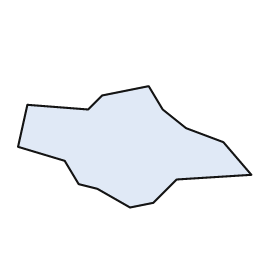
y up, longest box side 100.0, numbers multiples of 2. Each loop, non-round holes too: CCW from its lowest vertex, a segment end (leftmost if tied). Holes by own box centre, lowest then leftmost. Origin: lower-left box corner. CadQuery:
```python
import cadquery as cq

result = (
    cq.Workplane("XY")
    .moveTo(48.0, 0.0)
    .lineTo(58.0, 2.0)
    .lineTo(68.0, 12.0)
    .lineTo(100.0, 14.0)
    .lineTo(88.0, 28.0)
    .lineTo(72.0, 34.0)
    .lineTo(62.0, 42.0)
    .lineTo(56.0, 52.0)
    .lineTo(36.0, 48.0)
    .lineTo(30.0, 42.0)
    .lineTo(4.0, 44.0)
    .lineTo(0.0, 26.0)
    .lineTo(20.0, 20.0)
    .lineTo(26.0, 10.0)
    .lineTo(34.0, 8.0)
    .close()
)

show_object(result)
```